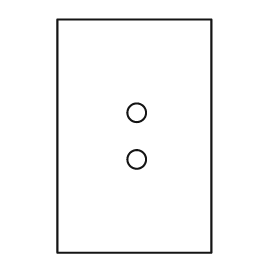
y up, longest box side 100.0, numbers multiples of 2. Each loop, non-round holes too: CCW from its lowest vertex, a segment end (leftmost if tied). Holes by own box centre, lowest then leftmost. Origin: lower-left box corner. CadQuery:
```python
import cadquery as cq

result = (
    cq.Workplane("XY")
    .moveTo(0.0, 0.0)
    .lineTo(66.0, 0.0)
    .lineTo(66.0, 100.0)
    .lineTo(0.0, 100.0)
    .close()
    .moveTo(34.0, 40.0)
    .circle(4.0)
    .moveTo(34.0, 60.0)
    .circle(4.0)
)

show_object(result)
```